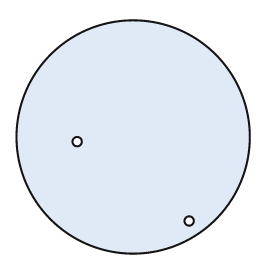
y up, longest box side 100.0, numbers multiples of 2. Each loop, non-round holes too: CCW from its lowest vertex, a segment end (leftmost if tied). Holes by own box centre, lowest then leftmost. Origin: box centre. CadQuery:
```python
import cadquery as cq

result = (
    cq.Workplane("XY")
    .moveTo(0.0, 0.0)
    .circle(50.0)
    .moveTo(24.0, -36.0)
    .circle(2.0)
    .moveTo(-24.0, -2.0)
    .circle(2.0)
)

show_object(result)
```